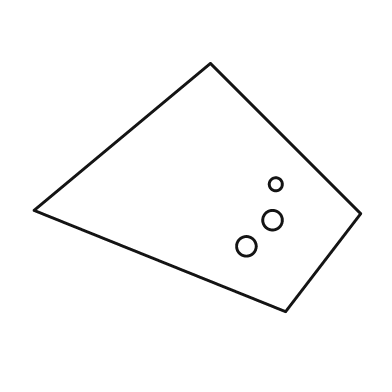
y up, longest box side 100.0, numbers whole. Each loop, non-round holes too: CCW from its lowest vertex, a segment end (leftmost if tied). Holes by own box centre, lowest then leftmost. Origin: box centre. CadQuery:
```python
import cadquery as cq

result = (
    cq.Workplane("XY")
    .moveTo(27.0, -38.0)
    .lineTo(50.0, -8.0)
    .lineTo(4.0, 38.0)
    .lineTo(-50.0, -7.0)
    .close()
    .moveTo(15.0, -18.0)
    .circle(3.0)
    .moveTo(23.0, -10.0)
    .circle(3.0)
    .moveTo(24.0, 1.0)
    .circle(2.0)
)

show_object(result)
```